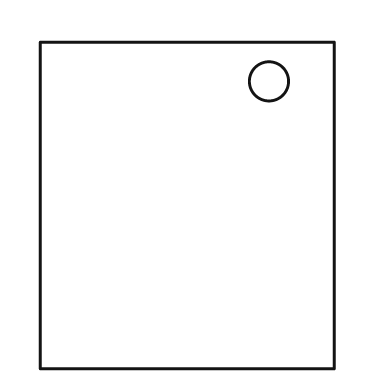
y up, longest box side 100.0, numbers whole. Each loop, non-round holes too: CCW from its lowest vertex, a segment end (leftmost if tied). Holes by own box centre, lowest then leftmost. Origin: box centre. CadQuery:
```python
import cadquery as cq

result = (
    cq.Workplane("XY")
    .moveTo(-45.0, -50.0)
    .lineTo(45.0, -50.0)
    .lineTo(45.0, 50.0)
    .lineTo(-45.0, 50.0)
    .close()
    .moveTo(25.0, 38.0)
    .circle(6.0)
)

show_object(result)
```